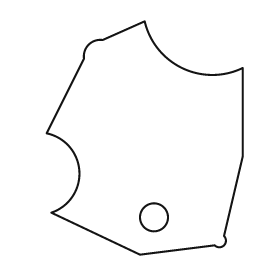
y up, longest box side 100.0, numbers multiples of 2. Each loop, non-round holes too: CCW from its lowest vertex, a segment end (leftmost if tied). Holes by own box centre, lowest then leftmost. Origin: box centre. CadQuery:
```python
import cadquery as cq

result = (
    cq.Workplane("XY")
    .moveTo(-2.0, -50.0)
    .lineTo(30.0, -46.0)
    .threePointArc((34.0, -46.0), (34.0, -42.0))
    .lineTo(42.0, -8.0)
    .lineTo(42.0, 30.0)
    .threePointArc((16.0, 30.0), (0.0, 50.0))
    .lineTo(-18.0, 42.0)
    .threePointArc((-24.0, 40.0), (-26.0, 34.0))
    .lineTo(-42.0, 2.0)
    .threePointArc((-28.0, -14.0), (-40.0, -32.0))
    .close()
    .moveTo(4.0, -34.0)
    .circle(6.0)
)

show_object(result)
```